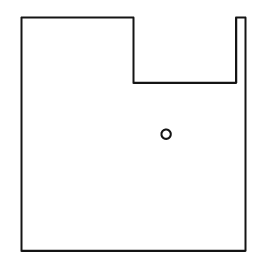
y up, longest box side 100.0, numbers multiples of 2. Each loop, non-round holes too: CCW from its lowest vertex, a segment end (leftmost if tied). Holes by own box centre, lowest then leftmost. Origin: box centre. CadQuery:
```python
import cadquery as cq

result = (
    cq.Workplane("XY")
    .moveTo(-48.0, -50.0)
    .lineTo(48.0, -50.0)
    .lineTo(48.0, 50.0)
    .lineTo(44.0, 50.0)
    .lineTo(44.0, 22.0)
    .lineTo(0.0, 22.0)
    .lineTo(0.0, 50.0)
    .lineTo(-48.0, 50.0)
    .close()
    .moveTo(14.0, 0.0)
    .circle(2.0)
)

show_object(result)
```